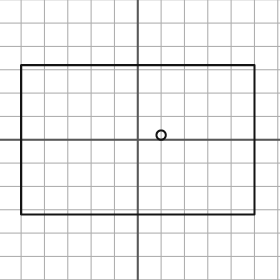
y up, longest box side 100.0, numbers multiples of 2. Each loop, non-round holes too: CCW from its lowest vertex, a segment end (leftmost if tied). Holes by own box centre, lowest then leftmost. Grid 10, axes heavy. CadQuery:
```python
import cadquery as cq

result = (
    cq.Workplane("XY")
    .moveTo(-50.0, -32.0)
    .lineTo(50.0, -32.0)
    .lineTo(50.0, 32.0)
    .lineTo(-50.0, 32.0)
    .close()
    .moveTo(10.0, 2.0)
    .circle(2.0)
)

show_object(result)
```